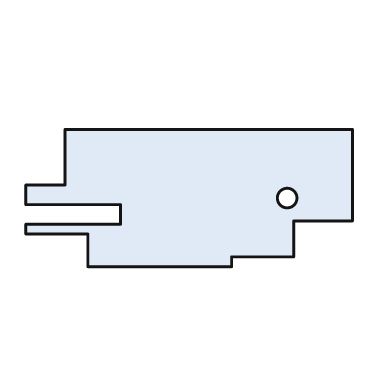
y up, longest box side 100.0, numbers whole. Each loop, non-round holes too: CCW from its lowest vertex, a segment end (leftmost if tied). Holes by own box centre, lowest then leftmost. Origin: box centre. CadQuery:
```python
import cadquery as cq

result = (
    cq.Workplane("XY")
    .moveTo(-31.0, -21.0)
    .lineTo(13.0, -21.0)
    .lineTo(13.0, -18.0)
    .lineTo(32.0, -18.0)
    .lineTo(32.0, -7.0)
    .lineTo(50.0, -7.0)
    .lineTo(50.0, 21.0)
    .lineTo(-38.0, 21.0)
    .lineTo(-38.0, 4.0)
    .lineTo(-50.0, 4.0)
    .lineTo(-50.0, -2.0)
    .lineTo(-21.0, -2.0)
    .lineTo(-21.0, -8.0)
    .lineTo(-50.0, -8.0)
    .lineTo(-50.0, -11.0)
    .lineTo(-31.0, -11.0)
    .close()
    .moveTo(30.0, 0.0)
    .circle(3.0)
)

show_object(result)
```